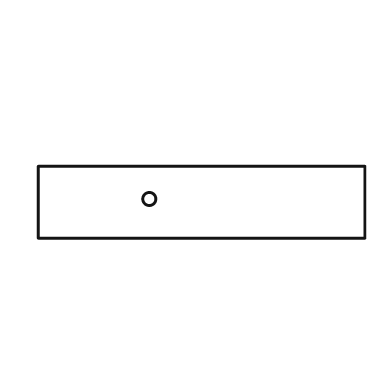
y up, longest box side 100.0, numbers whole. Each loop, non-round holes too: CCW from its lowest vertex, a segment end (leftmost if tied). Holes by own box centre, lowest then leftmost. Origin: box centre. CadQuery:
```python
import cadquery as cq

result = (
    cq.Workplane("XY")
    .moveTo(-50.0, -11.0)
    .lineTo(50.0, -11.0)
    .lineTo(50.0, 11.0)
    .lineTo(-50.0, 11.0)
    .close()
    .moveTo(-16.0, 1.0)
    .circle(2.0)
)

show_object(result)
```